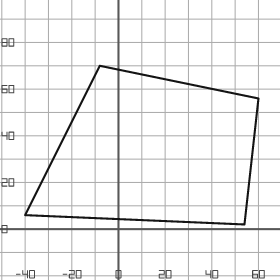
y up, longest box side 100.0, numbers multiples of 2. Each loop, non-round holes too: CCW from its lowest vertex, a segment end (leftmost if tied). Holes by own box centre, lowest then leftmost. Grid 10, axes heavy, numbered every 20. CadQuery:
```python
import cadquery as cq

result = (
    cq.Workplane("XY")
    .moveTo(54.0, 2.0)
    .lineTo(60.0, 56.0)
    .lineTo(-8.0, 70.0)
    .lineTo(-40.0, 6.0)
    .close()
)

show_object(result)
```